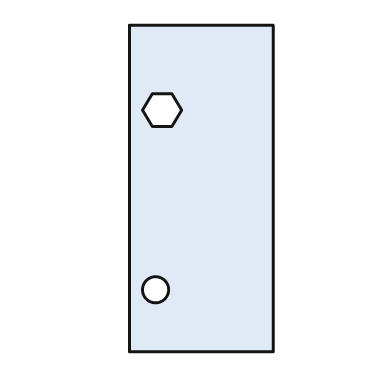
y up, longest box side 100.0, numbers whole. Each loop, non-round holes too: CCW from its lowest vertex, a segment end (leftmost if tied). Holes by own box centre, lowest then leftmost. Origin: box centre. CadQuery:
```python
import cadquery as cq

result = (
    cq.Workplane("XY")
    .moveTo(-22.0, -50.0)
    .lineTo(22.0, -50.0)
    .lineTo(22.0, 50.0)
    .lineTo(-22.0, 50.0)
    .close()
    .moveTo(-14.0, -31.0)
    .circle(4.0)
    .moveTo(-15.0, 19.0)
    .lineTo(-9.0, 19.0)
    .lineTo(-6.0, 24.0)
    .lineTo(-9.0, 29.0)
    .lineTo(-15.0, 29.0)
    .lineTo(-18.0, 24.0)
    .close()
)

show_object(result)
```